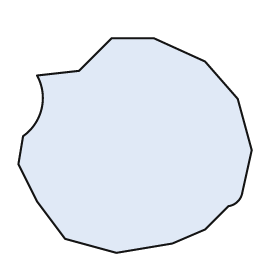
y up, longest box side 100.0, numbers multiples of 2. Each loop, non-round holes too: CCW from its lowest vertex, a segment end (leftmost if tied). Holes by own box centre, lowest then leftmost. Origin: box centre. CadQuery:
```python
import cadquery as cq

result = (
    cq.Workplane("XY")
    .moveTo(-8.0, -46.0)
    .lineTo(16.0, -42.0)
    .lineTo(30.0, -36.0)
    .lineTo(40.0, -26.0)
    .threePointArc((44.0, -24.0), (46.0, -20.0))
    .lineTo(50.0, -2.0)
    .lineTo(44.0, 20.0)
    .lineTo(30.0, 36.0)
    .lineTo(8.0, 46.0)
    .lineTo(-10.0, 46.0)
    .lineTo(-24.0, 32.0)
    .lineTo(-42.0, 30.0)
    .threePointArc((-40.0, 16.0), (-48.0, 4.0))
    .lineTo(-50.0, -8.0)
    .lineTo(-42.0, -24.0)
    .lineTo(-30.0, -40.0)
    .close()
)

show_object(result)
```